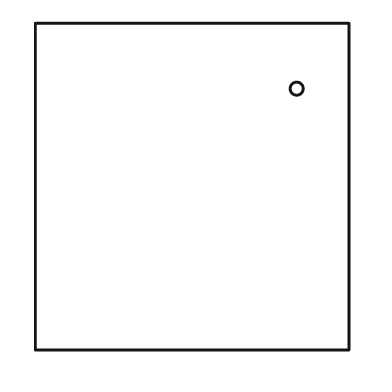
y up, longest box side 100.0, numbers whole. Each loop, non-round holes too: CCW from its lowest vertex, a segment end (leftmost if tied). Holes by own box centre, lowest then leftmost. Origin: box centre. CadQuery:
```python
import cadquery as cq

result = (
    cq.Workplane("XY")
    .moveTo(-48.0, -50.0)
    .lineTo(48.0, -50.0)
    .lineTo(48.0, 50.0)
    .lineTo(-48.0, 50.0)
    .close()
    .moveTo(32.0, 30.0)
    .circle(2.0)
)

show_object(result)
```